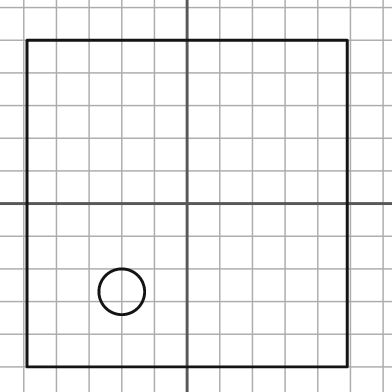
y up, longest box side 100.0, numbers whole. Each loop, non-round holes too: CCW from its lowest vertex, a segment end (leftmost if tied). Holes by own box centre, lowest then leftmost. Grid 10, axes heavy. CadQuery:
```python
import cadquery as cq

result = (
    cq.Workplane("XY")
    .moveTo(-49.0, -50.0)
    .lineTo(49.0, -50.0)
    .lineTo(49.0, 50.0)
    .lineTo(-49.0, 50.0)
    .close()
    .moveTo(-20.0, -27.0)
    .circle(7.0)
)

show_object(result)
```